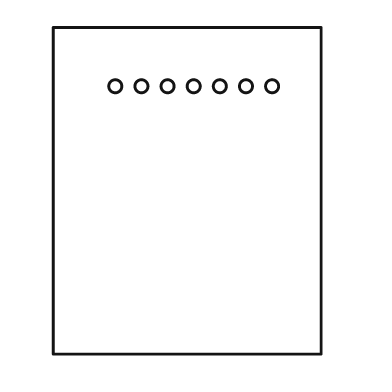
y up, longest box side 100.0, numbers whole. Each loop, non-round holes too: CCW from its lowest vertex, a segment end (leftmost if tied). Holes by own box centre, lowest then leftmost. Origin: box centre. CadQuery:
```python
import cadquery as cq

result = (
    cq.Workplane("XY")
    .moveTo(-41.0, -50.0)
    .lineTo(41.0, -50.0)
    .lineTo(41.0, 50.0)
    .lineTo(-41.0, 50.0)
    .close()
    .moveTo(-22.0, 32.0)
    .circle(2.0)
    .moveTo(-14.0, 32.0)
    .circle(2.0)
    .moveTo(-6.0, 32.0)
    .circle(2.0)
    .moveTo(2.0, 32.0)
    .circle(2.0)
    .moveTo(10.0, 32.0)
    .circle(2.0)
    .moveTo(18.0, 32.0)
    .circle(2.0)
    .moveTo(26.0, 32.0)
    .circle(2.0)
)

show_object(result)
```